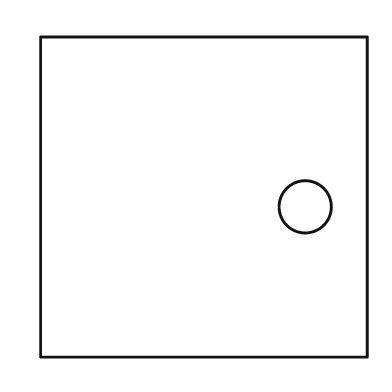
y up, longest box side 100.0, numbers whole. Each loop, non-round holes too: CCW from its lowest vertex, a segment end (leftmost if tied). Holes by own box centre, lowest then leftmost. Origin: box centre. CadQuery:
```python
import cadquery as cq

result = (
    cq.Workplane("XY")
    .moveTo(-50.0, -49.0)
    .lineTo(50.0, -49.0)
    .lineTo(50.0, 49.0)
    .lineTo(-50.0, 49.0)
    .close()
    .moveTo(31.0, -3.0)
    .circle(8.0)
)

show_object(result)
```